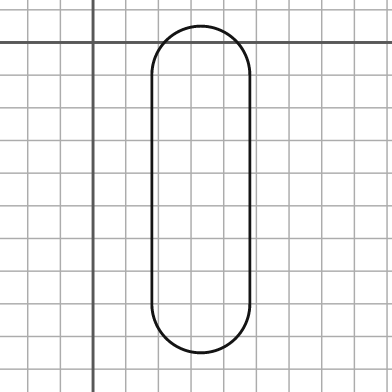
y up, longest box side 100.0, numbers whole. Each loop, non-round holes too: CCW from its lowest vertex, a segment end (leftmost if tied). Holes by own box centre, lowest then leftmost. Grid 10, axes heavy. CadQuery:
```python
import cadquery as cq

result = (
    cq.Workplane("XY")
    .moveTo(18.0, -80.0)
    .threePointArc((33.0, -95.0), (48.0, -80.0))
    .lineTo(48.0, -10.0)
    .threePointArc((33.0, 5.0), (18.0, -10.0))
    .close()
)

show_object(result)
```